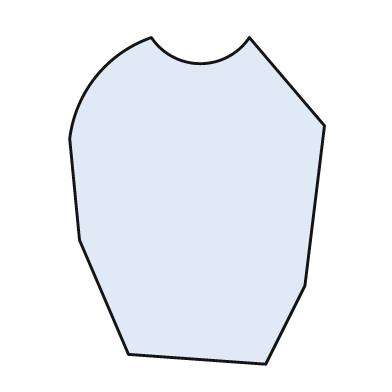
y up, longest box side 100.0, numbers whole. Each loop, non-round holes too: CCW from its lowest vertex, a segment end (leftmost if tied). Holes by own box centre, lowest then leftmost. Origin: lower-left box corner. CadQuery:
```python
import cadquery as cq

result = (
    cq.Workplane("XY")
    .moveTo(60.0, 0.0)
    .lineTo(72.0, 24.0)
    .lineTo(78.0, 73.0)
    .lineTo(55.0, 100.0)
    .threePointArc((40.0, 92.0), (25.0, 100.0))
    .threePointArc((8.0, 88.0), (0.0, 69.0))
    .lineTo(3.0, 38.0)
    .lineTo(18.0, 3.0)
    .close()
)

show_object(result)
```